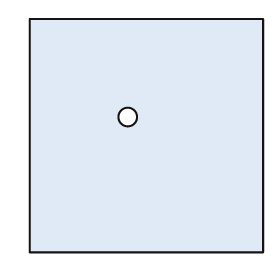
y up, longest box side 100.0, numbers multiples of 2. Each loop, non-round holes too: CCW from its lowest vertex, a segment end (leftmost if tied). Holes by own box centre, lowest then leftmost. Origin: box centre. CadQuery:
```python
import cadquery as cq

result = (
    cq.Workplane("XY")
    .moveTo(-50.0, -50.0)
    .lineTo(50.0, -50.0)
    .lineTo(50.0, 50.0)
    .lineTo(-50.0, 50.0)
    .close()
    .moveTo(-8.0, 8.0)
    .circle(4.0)
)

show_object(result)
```